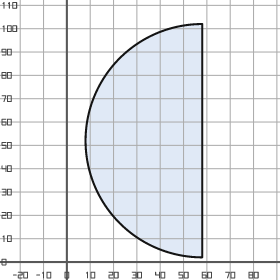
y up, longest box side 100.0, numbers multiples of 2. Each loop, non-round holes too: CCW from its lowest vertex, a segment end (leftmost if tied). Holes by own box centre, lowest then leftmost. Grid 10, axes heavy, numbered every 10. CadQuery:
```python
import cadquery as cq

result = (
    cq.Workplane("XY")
    .moveTo(58.0, 2.0)
    .lineTo(58.0, 102.0)
    .threePointArc((8.0, 52.0), (58.0, 2.0))
    .close()
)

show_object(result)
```